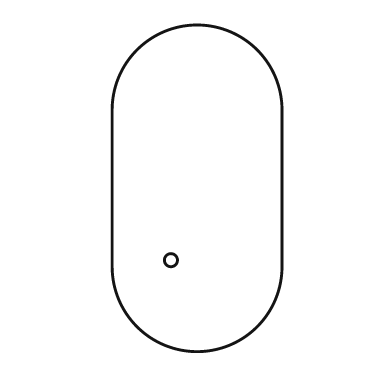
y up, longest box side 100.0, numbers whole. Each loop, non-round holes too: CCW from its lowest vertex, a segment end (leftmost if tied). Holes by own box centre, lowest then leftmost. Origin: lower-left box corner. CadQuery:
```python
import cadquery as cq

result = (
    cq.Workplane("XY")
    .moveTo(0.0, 26.0)
    .threePointArc((26.0, 0.0), (52.0, 26.0))
    .lineTo(52.0, 74.0)
    .threePointArc((26.0, 100.0), (0.0, 74.0))
    .close()
    .moveTo(18.0, 28.0)
    .circle(2.0)
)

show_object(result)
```